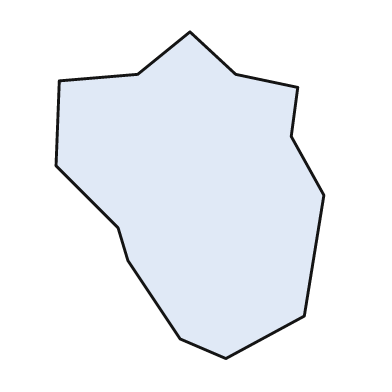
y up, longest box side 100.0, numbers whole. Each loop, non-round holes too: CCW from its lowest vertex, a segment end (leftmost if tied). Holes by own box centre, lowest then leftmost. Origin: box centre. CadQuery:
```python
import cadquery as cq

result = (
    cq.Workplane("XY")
    .moveTo(11.0, -50.0)
    .lineTo(35.0, -37.0)
    .lineTo(41.0, 0.0)
    .lineTo(31.0, 18.0)
    .lineTo(33.0, 33.0)
    .lineTo(14.0, 37.0)
    .lineTo(0.0, 50.0)
    .lineTo(-16.0, 37.0)
    .lineTo(-40.0, 35.0)
    .lineTo(-41.0, 9.0)
    .lineTo(-22.0, -10.0)
    .lineTo(-19.0, -20.0)
    .lineTo(-3.0, -44.0)
    .close()
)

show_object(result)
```